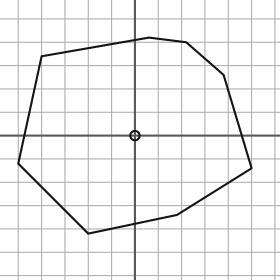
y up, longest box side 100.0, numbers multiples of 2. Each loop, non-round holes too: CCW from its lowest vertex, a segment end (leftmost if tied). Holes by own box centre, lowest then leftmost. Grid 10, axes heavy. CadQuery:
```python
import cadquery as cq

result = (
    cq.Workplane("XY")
    .moveTo(-20.0, -42.0)
    .lineTo(18.0, -34.0)
    .lineTo(50.0, -14.0)
    .lineTo(38.0, 26.0)
    .lineTo(22.0, 40.0)
    .lineTo(6.0, 42.0)
    .lineTo(-40.0, 34.0)
    .lineTo(-50.0, -12.0)
    .close()
    .moveTo(0.0, 0.0)
    .circle(2.0)
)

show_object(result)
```